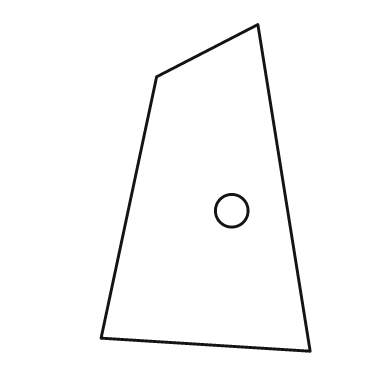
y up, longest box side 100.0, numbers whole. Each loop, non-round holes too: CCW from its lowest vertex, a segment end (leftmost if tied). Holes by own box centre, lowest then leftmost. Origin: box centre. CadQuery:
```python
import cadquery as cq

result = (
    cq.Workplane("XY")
    .moveTo(32.0, -50.0)
    .lineTo(16.0, 50.0)
    .lineTo(-15.0, 34.0)
    .lineTo(-32.0, -46.0)
    .close()
    .moveTo(8.0, -7.0)
    .circle(5.0)
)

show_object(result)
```